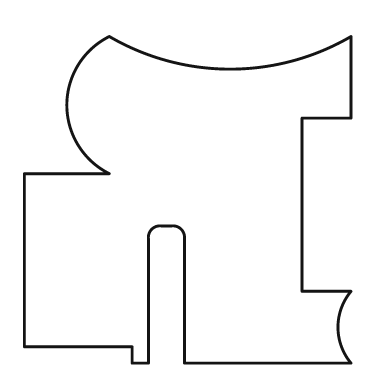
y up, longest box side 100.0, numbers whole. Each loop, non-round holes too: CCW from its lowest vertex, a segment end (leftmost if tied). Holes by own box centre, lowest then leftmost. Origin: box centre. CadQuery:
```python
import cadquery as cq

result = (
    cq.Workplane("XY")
    .moveTo(-17.0, -50.0)
    .lineTo(-12.0, -50.0)
    .lineTo(-12.0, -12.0)
    .threePointArc((-11.0, -9.0), (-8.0, -8.0))
    .lineTo(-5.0, -8.0)
    .threePointArc((-2.0, -9.0), (-1.0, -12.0))
    .lineTo(-1.0, -50.0)
    .lineTo(50.0, -50.0)
    .threePointArc((46.0, -39.0), (50.0, -28.0))
    .lineTo(35.0, -28.0)
    .lineTo(35.0, 25.0)
    .lineTo(50.0, 25.0)
    .lineTo(50.0, 50.0)
    .threePointArc((13.0, 40.0), (-24.0, 50.0))
    .threePointArc((-37.0, 29.0), (-24.0, 8.0))
    .lineTo(-50.0, 8.0)
    .lineTo(-50.0, -45.0)
    .lineTo(-17.0, -45.0)
    .close()
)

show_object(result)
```